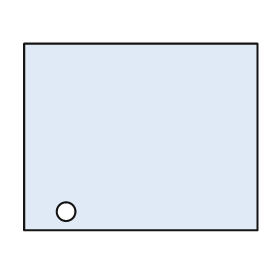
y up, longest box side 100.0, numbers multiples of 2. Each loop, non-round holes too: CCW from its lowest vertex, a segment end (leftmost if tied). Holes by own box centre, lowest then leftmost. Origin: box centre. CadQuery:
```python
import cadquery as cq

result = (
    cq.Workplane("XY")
    .moveTo(-50.0, -40.0)
    .lineTo(50.0, -40.0)
    .lineTo(50.0, 40.0)
    .lineTo(-50.0, 40.0)
    .close()
    .moveTo(-32.0, -32.0)
    .circle(4.0)
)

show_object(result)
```